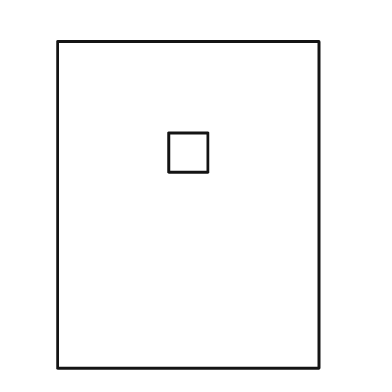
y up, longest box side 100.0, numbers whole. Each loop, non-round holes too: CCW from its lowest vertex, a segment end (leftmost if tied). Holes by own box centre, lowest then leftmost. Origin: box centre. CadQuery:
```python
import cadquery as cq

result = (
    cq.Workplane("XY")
    .moveTo(-40.0, -50.0)
    .lineTo(40.0, -50.0)
    .lineTo(40.0, 50.0)
    .lineTo(-40.0, 50.0)
    .close()
    .moveTo(-6.0, 10.0)
    .lineTo(6.0, 10.0)
    .lineTo(6.0, 22.0)
    .lineTo(-6.0, 22.0)
    .close()
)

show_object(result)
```